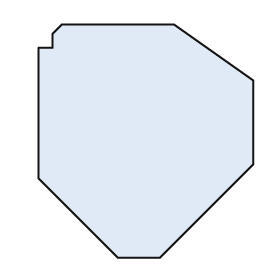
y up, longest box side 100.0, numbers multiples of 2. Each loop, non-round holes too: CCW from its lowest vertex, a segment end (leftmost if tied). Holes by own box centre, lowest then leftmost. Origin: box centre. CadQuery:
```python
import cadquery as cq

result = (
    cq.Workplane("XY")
    .moveTo(-12.0, -50.0)
    .lineTo(6.0, -50.0)
    .lineTo(46.0, -10.0)
    .lineTo(46.0, 26.0)
    .lineTo(12.0, 50.0)
    .lineTo(-36.0, 50.0)
    .lineTo(-40.0, 46.0)
    .lineTo(-40.0, 40.0)
    .lineTo(-46.0, 40.0)
    .lineTo(-46.0, -16.0)
    .close()
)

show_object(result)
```